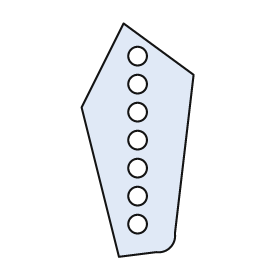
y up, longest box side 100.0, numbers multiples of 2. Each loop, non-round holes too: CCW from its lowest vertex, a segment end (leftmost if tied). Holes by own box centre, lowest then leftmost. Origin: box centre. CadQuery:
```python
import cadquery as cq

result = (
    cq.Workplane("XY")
    .moveTo(-8.0, -50.0)
    .lineTo(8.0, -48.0)
    .threePointArc((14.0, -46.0), (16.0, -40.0))
    .lineTo(24.0, 28.0)
    .lineTo(-6.0, 50.0)
    .lineTo(-24.0, 14.0)
    .close()
    .moveTo(0.0, -36.0)
    .circle(4.0)
    .moveTo(0.0, -24.0)
    .circle(4.0)
    .moveTo(0.0, -12.0)
    .circle(4.0)
    .moveTo(0.0, 0.0)
    .circle(4.0)
    .moveTo(0.0, 12.0)
    .circle(4.0)
    .moveTo(0.0, 24.0)
    .circle(4.0)
    .moveTo(0.0, 36.0)
    .circle(4.0)
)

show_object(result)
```